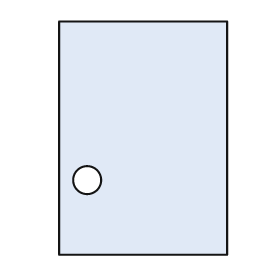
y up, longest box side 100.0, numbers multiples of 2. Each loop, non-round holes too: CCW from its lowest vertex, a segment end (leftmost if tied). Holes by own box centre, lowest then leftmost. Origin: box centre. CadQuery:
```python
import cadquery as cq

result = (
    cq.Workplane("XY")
    .moveTo(-36.0, -50.0)
    .lineTo(36.0, -50.0)
    .lineTo(36.0, 50.0)
    .lineTo(-36.0, 50.0)
    .close()
    .moveTo(-24.0, -18.0)
    .circle(6.0)
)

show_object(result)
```